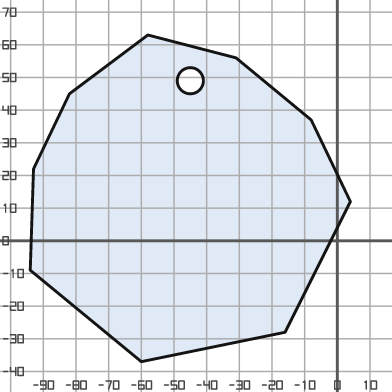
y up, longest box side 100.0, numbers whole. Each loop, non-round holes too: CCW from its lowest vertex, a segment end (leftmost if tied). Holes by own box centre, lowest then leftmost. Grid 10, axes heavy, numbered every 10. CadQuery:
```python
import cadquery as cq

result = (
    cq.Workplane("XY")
    .moveTo(-60.0, -37.0)
    .lineTo(-16.0, -28.0)
    .lineTo(4.0, 12.0)
    .lineTo(-8.0, 37.0)
    .lineTo(-31.0, 56.0)
    .lineTo(-58.0, 63.0)
    .lineTo(-82.0, 45.0)
    .lineTo(-93.0, 22.0)
    .lineTo(-94.0, -9.0)
    .close()
    .moveTo(-45.0, 49.0)
    .circle(4.0)
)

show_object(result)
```